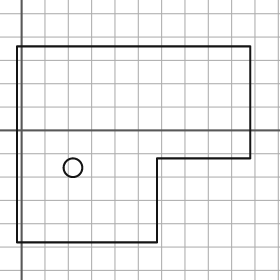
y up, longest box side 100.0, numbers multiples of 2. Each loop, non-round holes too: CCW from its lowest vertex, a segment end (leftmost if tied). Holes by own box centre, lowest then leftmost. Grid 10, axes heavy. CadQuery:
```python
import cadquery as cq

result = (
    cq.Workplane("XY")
    .moveTo(-2.0, -48.0)
    .lineTo(58.0, -48.0)
    .lineTo(58.0, -12.0)
    .lineTo(98.0, -12.0)
    .lineTo(98.0, 36.0)
    .lineTo(-2.0, 36.0)
    .close()
    .moveTo(22.0, -16.0)
    .circle(4.0)
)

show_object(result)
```